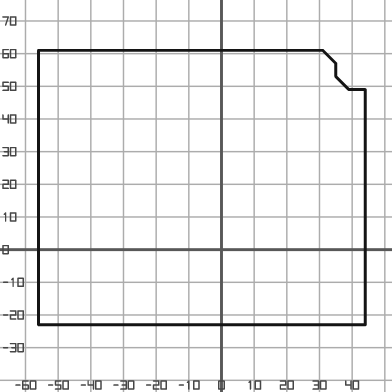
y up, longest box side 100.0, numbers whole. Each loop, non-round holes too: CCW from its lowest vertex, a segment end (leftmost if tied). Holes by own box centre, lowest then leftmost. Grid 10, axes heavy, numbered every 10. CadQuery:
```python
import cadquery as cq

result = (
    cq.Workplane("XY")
    .moveTo(-56.0, -23.0)
    .lineTo(44.0, -23.0)
    .lineTo(44.0, 49.0)
    .lineTo(39.0, 49.0)
    .lineTo(35.0, 53.0)
    .lineTo(35.0, 57.0)
    .lineTo(31.0, 61.0)
    .lineTo(-56.0, 61.0)
    .close()
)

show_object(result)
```